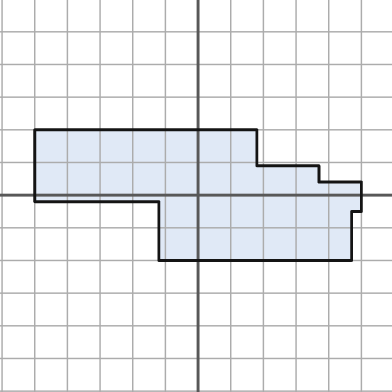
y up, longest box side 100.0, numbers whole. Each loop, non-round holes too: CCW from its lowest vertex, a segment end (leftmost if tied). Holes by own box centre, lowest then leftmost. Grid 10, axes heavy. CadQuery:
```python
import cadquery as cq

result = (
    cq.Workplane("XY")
    .moveTo(-12.0, -20.0)
    .lineTo(47.0, -20.0)
    .lineTo(47.0, -5.0)
    .lineTo(50.0, -5.0)
    .lineTo(50.0, 4.0)
    .lineTo(37.0, 4.0)
    .lineTo(37.0, 9.0)
    .lineTo(18.0, 9.0)
    .lineTo(18.0, 20.0)
    .lineTo(-50.0, 20.0)
    .lineTo(-50.0, -2.0)
    .lineTo(-12.0, -2.0)
    .close()
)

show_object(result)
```